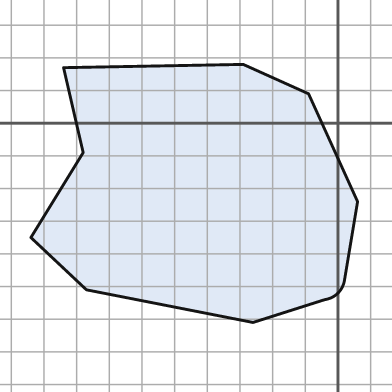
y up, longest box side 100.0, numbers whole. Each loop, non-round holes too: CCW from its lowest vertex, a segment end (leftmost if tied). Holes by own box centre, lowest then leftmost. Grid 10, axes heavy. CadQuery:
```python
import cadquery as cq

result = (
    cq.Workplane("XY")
    .moveTo(-26.0, -61.0)
    .lineTo(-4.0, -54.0)
    .threePointArc((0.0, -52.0), (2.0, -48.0))
    .lineTo(6.0, -24.0)
    .lineTo(-9.0, 9.0)
    .lineTo(-29.0, 18.0)
    .lineTo(-84.0, 17.0)
    .lineTo(-78.0, -9.0)
    .lineTo(-94.0, -35.0)
    .lineTo(-77.0, -51.0)
    .close()
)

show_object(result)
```